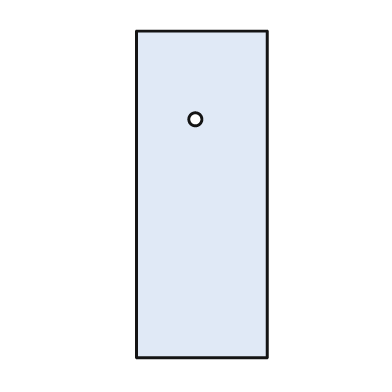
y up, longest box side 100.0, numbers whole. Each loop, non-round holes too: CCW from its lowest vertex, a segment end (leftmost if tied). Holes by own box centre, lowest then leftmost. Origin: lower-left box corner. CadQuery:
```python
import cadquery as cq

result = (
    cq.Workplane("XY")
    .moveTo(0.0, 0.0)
    .lineTo(40.0, 0.0)
    .lineTo(40.0, 100.0)
    .lineTo(0.0, 100.0)
    .close()
    .moveTo(18.0, 73.0)
    .circle(2.0)
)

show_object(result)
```